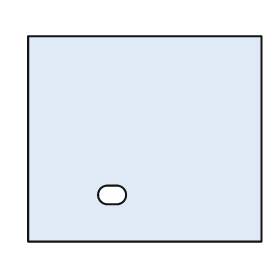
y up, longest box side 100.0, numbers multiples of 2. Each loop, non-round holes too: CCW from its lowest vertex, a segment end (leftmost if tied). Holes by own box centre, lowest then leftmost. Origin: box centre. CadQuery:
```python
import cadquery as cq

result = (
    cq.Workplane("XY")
    .moveTo(-50.0, -44.0)
    .lineTo(50.0, -44.0)
    .lineTo(50.0, 44.0)
    .lineTo(-50.0, 44.0)
    .close()
    .moveTo(-16.0, -28.0)
    .lineTo(-12.0, -28.0)
    .threePointArc((-8.0, -24.0), (-12.0, -20.0))
    .lineTo(-16.0, -20.0)
    .threePointArc((-20.0, -24.0), (-16.0, -28.0))
    .close()
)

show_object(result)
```